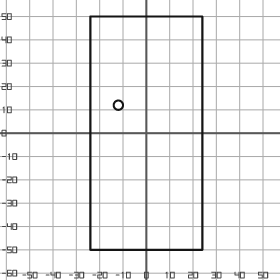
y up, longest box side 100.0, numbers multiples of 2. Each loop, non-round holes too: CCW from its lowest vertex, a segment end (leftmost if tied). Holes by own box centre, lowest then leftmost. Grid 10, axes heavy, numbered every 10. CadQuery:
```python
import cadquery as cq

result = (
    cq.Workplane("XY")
    .moveTo(-24.0, -50.0)
    .lineTo(24.0, -50.0)
    .lineTo(24.0, 50.0)
    .lineTo(-24.0, 50.0)
    .close()
    .moveTo(-12.0, 12.0)
    .circle(2.0)
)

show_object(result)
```